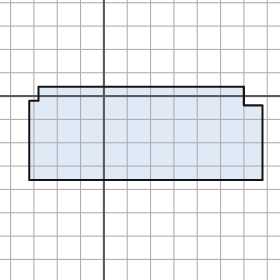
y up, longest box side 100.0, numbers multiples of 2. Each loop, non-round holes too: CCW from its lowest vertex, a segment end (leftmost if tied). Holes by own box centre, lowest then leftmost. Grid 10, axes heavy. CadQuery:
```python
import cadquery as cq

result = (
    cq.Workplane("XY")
    .moveTo(-32.0, -36.0)
    .lineTo(68.0, -36.0)
    .lineTo(68.0, -4.0)
    .lineTo(60.0, -4.0)
    .lineTo(60.0, 4.0)
    .lineTo(-28.0, 4.0)
    .lineTo(-28.0, -2.0)
    .lineTo(-32.0, -2.0)
    .close()
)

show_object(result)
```